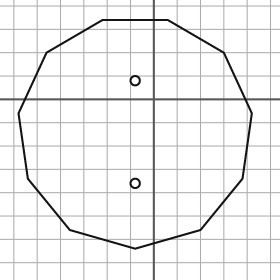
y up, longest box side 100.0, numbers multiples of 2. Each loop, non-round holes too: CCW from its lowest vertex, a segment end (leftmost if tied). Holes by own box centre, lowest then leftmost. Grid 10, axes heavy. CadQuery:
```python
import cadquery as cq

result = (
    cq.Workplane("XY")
    .moveTo(-8.0, -64.0)
    .lineTo(20.0, -56.0)
    .lineTo(38.0, -34.0)
    .lineTo(42.0, -6.0)
    .lineTo(30.0, 20.0)
    .lineTo(6.0, 34.0)
    .lineTo(-22.0, 34.0)
    .lineTo(-46.0, 20.0)
    .lineTo(-58.0, -6.0)
    .lineTo(-54.0, -34.0)
    .lineTo(-36.0, -56.0)
    .close()
    .moveTo(-8.0, -36.0)
    .circle(2.0)
    .moveTo(-8.0, 8.0)
    .circle(2.0)
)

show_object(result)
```